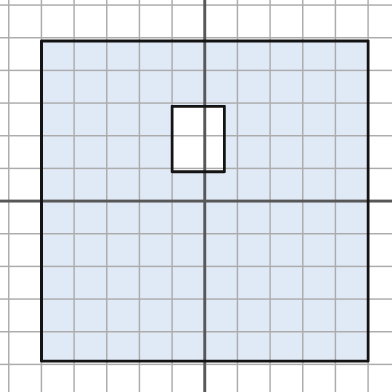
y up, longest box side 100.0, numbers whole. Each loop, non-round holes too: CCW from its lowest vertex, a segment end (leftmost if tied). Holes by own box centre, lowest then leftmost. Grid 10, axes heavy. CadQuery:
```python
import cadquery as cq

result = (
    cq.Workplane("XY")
    .moveTo(-50.0, -49.0)
    .lineTo(50.0, -49.0)
    .lineTo(50.0, 49.0)
    .lineTo(-50.0, 49.0)
    .close()
    .moveTo(-10.0, 9.0)
    .lineTo(6.0, 9.0)
    .lineTo(6.0, 29.0)
    .lineTo(-10.0, 29.0)
    .close()
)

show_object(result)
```